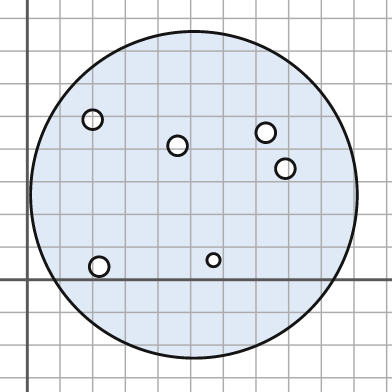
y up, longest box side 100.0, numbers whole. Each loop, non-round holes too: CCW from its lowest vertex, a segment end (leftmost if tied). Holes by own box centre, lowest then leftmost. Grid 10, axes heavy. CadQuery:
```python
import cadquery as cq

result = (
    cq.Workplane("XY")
    .moveTo(51.0, 26.0)
    .circle(50.0)
    .moveTo(22.0, 4.0)
    .circle(3.0)
    .moveTo(57.0, 6.0)
    .circle(2.0)
    .moveTo(79.0, 34.0)
    .circle(3.0)
    .moveTo(46.0, 41.0)
    .circle(3.0)
    .moveTo(73.0, 45.0)
    .circle(3.0)
    .moveTo(20.0, 49.0)
    .circle(3.0)
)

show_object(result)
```